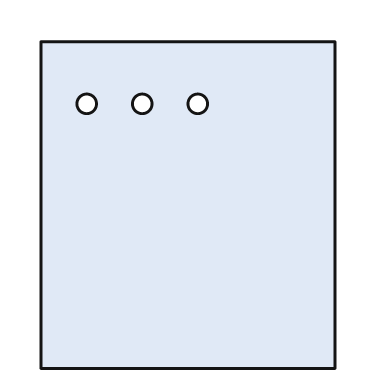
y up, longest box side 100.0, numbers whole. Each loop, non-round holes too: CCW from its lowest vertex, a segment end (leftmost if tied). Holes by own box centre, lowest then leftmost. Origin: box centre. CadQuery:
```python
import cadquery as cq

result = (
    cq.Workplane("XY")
    .moveTo(-45.0, -50.0)
    .lineTo(45.0, -50.0)
    .lineTo(45.0, 50.0)
    .lineTo(-45.0, 50.0)
    .close()
    .moveTo(-31.0, 31.0)
    .circle(3.0)
    .moveTo(-14.0, 31.0)
    .circle(3.0)
    .moveTo(3.0, 31.0)
    .circle(3.0)
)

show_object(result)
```